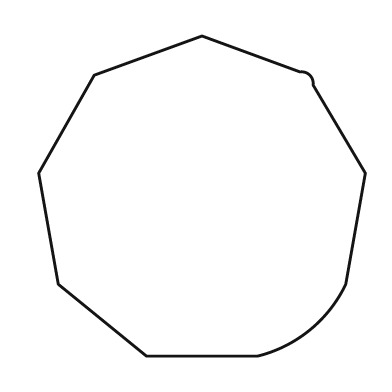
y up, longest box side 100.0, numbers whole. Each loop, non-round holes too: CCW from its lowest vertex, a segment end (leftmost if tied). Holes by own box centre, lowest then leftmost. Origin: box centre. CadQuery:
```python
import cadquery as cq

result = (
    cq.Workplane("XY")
    .moveTo(-17.0, -49.0)
    .lineTo(17.0, -49.0)
    .threePointArc((33.0, -41.0), (44.0, -27.0))
    .lineTo(50.0, 7.0)
    .lineTo(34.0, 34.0)
    .threePointArc((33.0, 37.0), (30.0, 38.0))
    .lineTo(0.0, 49.0)
    .lineTo(-33.0, 37.0)
    .lineTo(-50.0, 7.0)
    .lineTo(-44.0, -27.0)
    .close()
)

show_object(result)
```